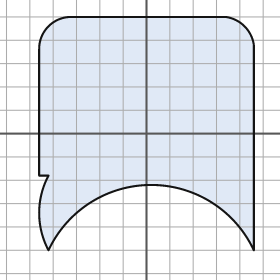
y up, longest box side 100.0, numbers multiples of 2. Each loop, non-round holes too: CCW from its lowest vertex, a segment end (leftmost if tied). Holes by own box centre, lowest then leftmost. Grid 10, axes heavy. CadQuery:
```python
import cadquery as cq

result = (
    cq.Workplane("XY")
    .moveTo(-42.0, -50.0)
    .threePointArc((2.0, -22.0), (46.0, -50.0))
    .lineTo(46.0, 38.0)
    .threePointArc((42.0, 46.0), (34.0, 50.0))
    .lineTo(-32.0, 50.0)
    .threePointArc((-42.0, 46.0), (-46.0, 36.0))
    .lineTo(-46.0, -18.0)
    .lineTo(-42.0, -18.0)
    .threePointArc((-46.0, -34.0), (-42.0, -50.0))
    .close()
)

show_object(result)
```